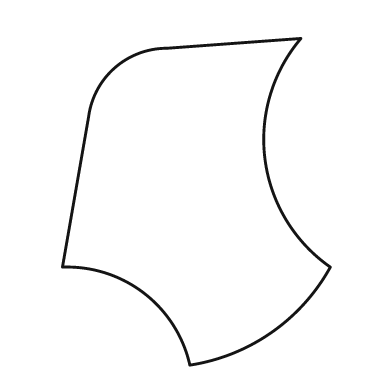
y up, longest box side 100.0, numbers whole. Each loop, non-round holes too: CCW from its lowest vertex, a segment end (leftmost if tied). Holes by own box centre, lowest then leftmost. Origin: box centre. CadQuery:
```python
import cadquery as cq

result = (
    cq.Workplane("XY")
    .moveTo(-2.0, -50.0)
    .threePointArc((23.0, -40.0), (41.0, -20.0))
    .threePointArc((21.0, 13.0), (32.0, 50.0))
    .lineTo(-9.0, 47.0)
    .threePointArc((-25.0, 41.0), (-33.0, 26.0))
    .lineTo(-41.0, -20.0)
    .threePointArc((-16.0, -28.0), (-2.0, -50.0))
    .close()
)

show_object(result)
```